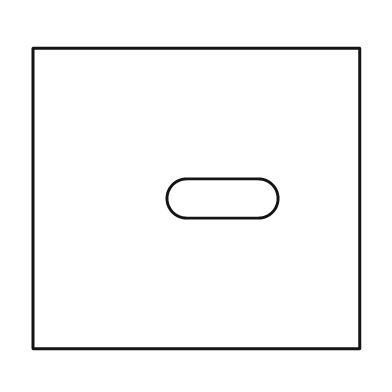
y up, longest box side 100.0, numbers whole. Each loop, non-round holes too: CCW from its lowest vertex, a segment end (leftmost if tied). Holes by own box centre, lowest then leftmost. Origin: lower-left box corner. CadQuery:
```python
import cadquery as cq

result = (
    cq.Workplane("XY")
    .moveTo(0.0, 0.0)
    .lineTo(100.0, 0.0)
    .lineTo(100.0, 92.0)
    .lineTo(0.0, 92.0)
    .close()
    .moveTo(47.0, 40.0)
    .lineTo(69.0, 40.0)
    .threePointArc((75.0, 46.0), (69.0, 52.0))
    .lineTo(47.0, 52.0)
    .threePointArc((41.0, 46.0), (47.0, 40.0))
    .close()
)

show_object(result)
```